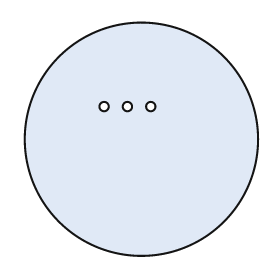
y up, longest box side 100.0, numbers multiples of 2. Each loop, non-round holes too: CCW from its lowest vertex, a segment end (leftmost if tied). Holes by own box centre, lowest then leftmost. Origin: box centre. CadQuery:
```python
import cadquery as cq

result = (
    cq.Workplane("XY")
    .moveTo(0.0, 0.0)
    .circle(50.0)
    .moveTo(-16.0, 14.0)
    .circle(2.0)
    .moveTo(-6.0, 14.0)
    .circle(2.0)
    .moveTo(4.0, 14.0)
    .circle(2.0)
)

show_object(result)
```